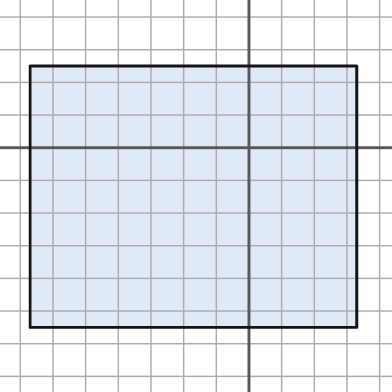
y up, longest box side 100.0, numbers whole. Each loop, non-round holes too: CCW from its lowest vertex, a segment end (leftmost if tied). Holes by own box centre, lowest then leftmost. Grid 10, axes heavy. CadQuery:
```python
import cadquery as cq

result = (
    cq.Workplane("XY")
    .moveTo(-67.0, -55.0)
    .lineTo(33.0, -55.0)
    .lineTo(33.0, 25.0)
    .lineTo(-67.0, 25.0)
    .close()
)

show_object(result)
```